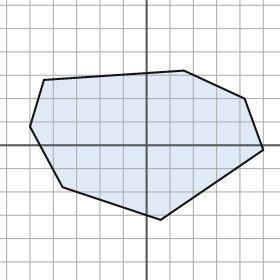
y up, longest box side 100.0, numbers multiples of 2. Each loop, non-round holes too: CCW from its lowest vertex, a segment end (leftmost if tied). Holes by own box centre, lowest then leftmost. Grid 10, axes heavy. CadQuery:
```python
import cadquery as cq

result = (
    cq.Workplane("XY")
    .moveTo(6.0, -32.0)
    .lineTo(50.0, -2.0)
    .lineTo(42.0, 20.0)
    .lineTo(16.0, 32.0)
    .lineTo(-44.0, 28.0)
    .lineTo(-50.0, 8.0)
    .lineTo(-36.0, -18.0)
    .close()
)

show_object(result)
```